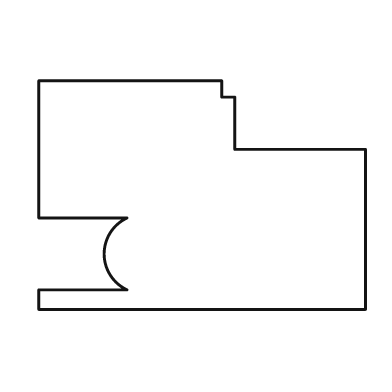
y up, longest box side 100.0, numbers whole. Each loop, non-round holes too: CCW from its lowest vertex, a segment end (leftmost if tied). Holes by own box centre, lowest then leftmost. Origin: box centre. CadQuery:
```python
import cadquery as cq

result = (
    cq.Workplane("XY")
    .moveTo(-50.0, -35.0)
    .lineTo(50.0, -35.0)
    .lineTo(50.0, 14.0)
    .lineTo(10.0, 14.0)
    .lineTo(10.0, 30.0)
    .lineTo(6.0, 30.0)
    .lineTo(6.0, 35.0)
    .lineTo(-50.0, 35.0)
    .lineTo(-50.0, -7.0)
    .lineTo(-23.0, -7.0)
    .threePointArc((-30.0, -18.0), (-23.0, -29.0))
    .lineTo(-50.0, -29.0)
    .close()
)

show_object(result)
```